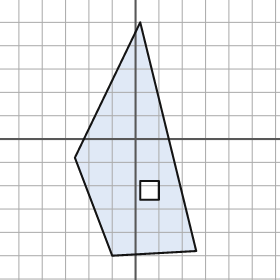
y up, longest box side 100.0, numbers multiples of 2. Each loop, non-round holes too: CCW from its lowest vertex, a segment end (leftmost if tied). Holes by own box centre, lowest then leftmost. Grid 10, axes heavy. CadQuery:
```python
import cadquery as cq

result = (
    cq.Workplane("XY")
    .moveTo(-10.0, -50.0)
    .lineTo(26.0, -48.0)
    .lineTo(2.0, 50.0)
    .lineTo(-26.0, -8.0)
    .close()
    .moveTo(2.0, -26.0)
    .lineTo(10.0, -26.0)
    .lineTo(10.0, -18.0)
    .lineTo(2.0, -18.0)
    .close()
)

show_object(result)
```